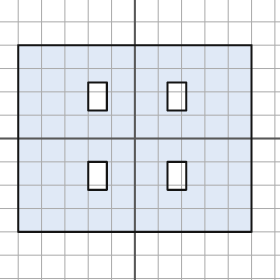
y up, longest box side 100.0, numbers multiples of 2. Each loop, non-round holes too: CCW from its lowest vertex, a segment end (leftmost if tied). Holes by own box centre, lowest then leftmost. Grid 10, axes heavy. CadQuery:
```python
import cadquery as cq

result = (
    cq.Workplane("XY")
    .moveTo(-50.0, -40.0)
    .lineTo(50.0, -40.0)
    .lineTo(50.0, 40.0)
    .lineTo(-50.0, 40.0)
    .close()
    .moveTo(-20.0, -22.0)
    .lineTo(-12.0, -22.0)
    .lineTo(-12.0, -10.0)
    .lineTo(-20.0, -10.0)
    .close()
    .moveTo(14.0, -22.0)
    .lineTo(22.0, -22.0)
    .lineTo(22.0, -10.0)
    .lineTo(14.0, -10.0)
    .close()
    .moveTo(-20.0, 12.0)
    .lineTo(-12.0, 12.0)
    .lineTo(-12.0, 24.0)
    .lineTo(-20.0, 24.0)
    .close()
    .moveTo(14.0, 12.0)
    .lineTo(22.0, 12.0)
    .lineTo(22.0, 24.0)
    .lineTo(14.0, 24.0)
    .close()
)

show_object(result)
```